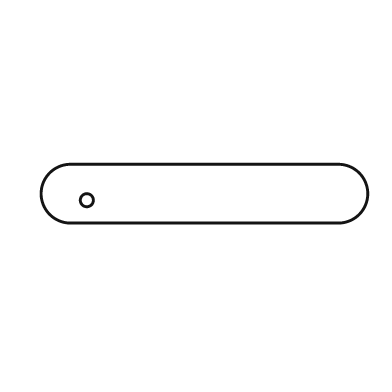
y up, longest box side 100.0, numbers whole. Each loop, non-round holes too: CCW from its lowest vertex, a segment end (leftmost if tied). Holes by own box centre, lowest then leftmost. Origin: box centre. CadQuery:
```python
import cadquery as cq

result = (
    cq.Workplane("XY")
    .moveTo(-41.0, -9.0)
    .lineTo(41.0, -9.0)
    .threePointArc((50.0, 0.0), (41.0, 9.0))
    .lineTo(-41.0, 9.0)
    .threePointArc((-50.0, 0.0), (-41.0, -9.0))
    .close()
    .moveTo(-36.0, -2.0)
    .circle(2.0)
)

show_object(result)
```